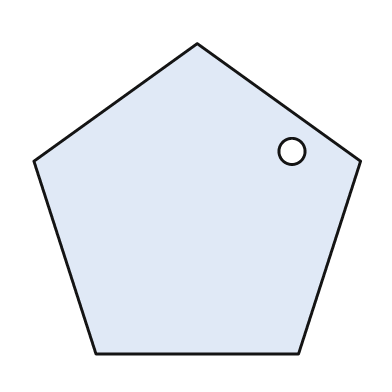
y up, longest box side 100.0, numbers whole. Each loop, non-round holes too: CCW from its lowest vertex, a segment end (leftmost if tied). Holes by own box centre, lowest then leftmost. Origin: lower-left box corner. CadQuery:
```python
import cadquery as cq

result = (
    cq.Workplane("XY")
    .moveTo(19.0, 0.0)
    .lineTo(81.0, 0.0)
    .lineTo(100.0, 59.0)
    .lineTo(50.0, 95.0)
    .lineTo(0.0, 59.0)
    .close()
    .moveTo(79.0, 62.0)
    .circle(4.0)
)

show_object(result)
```